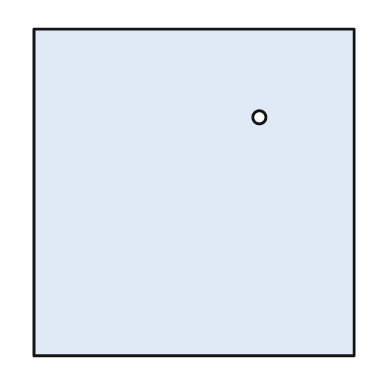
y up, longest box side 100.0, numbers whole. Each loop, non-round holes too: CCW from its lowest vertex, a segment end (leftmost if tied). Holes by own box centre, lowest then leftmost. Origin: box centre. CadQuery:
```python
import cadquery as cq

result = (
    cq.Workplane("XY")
    .moveTo(-49.0, -50.0)
    .lineTo(49.0, -50.0)
    .lineTo(49.0, 50.0)
    .lineTo(-49.0, 50.0)
    .close()
    .moveTo(20.0, 23.0)
    .circle(2.0)
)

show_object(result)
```